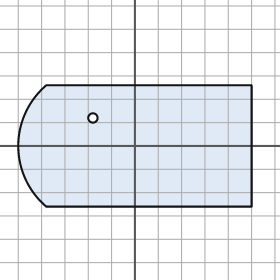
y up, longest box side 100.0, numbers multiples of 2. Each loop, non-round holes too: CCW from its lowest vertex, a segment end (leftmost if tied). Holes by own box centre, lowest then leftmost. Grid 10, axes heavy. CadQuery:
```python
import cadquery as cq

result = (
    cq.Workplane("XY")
    .moveTo(-38.0, -26.0)
    .lineTo(50.0, -26.0)
    .lineTo(50.0, 26.0)
    .lineTo(-38.0, 26.0)
    .threePointArc((-50.0, 0.0), (-38.0, -26.0))
    .close()
    .moveTo(-18.0, 12.0)
    .circle(2.0)
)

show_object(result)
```